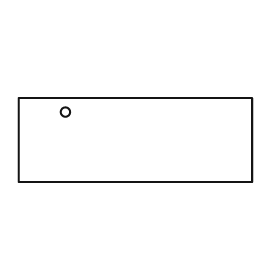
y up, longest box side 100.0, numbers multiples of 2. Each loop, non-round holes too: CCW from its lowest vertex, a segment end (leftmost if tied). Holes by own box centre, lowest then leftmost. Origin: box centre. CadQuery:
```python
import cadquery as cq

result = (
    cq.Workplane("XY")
    .moveTo(-50.0, -18.0)
    .lineTo(50.0, -18.0)
    .lineTo(50.0, 18.0)
    .lineTo(-50.0, 18.0)
    .close()
    .moveTo(-30.0, 12.0)
    .circle(2.0)
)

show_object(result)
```